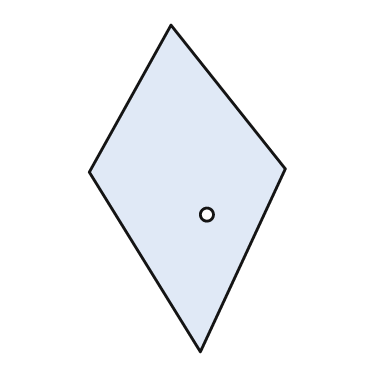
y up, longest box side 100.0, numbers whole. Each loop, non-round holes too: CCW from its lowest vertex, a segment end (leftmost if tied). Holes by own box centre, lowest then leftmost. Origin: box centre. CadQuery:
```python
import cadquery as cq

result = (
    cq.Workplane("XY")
    .moveTo(4.0, -50.0)
    .lineTo(30.0, 6.0)
    .lineTo(-5.0, 50.0)
    .lineTo(-30.0, 5.0)
    .close()
    .moveTo(6.0, -8.0)
    .circle(2.0)
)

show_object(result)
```